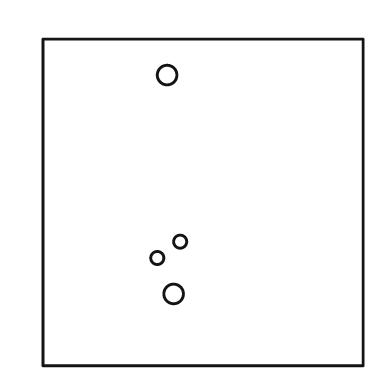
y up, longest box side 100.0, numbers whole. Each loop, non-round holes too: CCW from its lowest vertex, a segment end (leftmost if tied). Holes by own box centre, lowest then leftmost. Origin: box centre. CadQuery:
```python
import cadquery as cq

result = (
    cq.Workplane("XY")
    .moveTo(-49.0, -50.0)
    .lineTo(49.0, -50.0)
    .lineTo(49.0, 50.0)
    .lineTo(-49.0, 50.0)
    .close()
    .moveTo(-9.0, -28.0)
    .circle(3.0)
    .moveTo(-14.0, -17.0)
    .circle(2.0)
    .moveTo(-7.0, -12.0)
    .circle(2.0)
    .moveTo(-11.0, 39.0)
    .circle(3.0)
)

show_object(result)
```